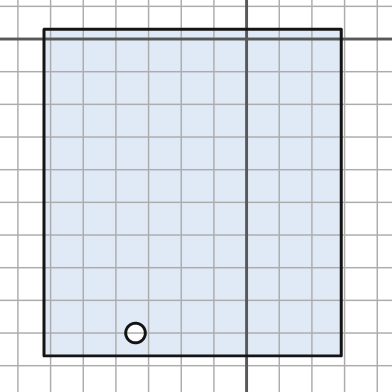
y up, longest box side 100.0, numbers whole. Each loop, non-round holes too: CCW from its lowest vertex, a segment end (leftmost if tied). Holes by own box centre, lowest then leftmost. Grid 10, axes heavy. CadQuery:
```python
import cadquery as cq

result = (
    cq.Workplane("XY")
    .moveTo(-62.0, -97.0)
    .lineTo(29.0, -97.0)
    .lineTo(29.0, 3.0)
    .lineTo(-62.0, 3.0)
    .close()
    .moveTo(-34.0, -90.0)
    .circle(3.0)
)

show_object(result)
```